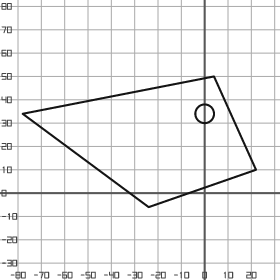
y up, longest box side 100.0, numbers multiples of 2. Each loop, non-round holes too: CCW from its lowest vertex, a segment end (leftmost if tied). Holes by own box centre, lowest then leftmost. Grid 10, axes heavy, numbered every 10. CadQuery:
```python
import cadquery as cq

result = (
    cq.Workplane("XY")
    .moveTo(-24.0, -6.0)
    .lineTo(22.0, 10.0)
    .lineTo(4.0, 50.0)
    .lineTo(-78.0, 34.0)
    .close()
    .moveTo(0.0, 34.0)
    .circle(4.0)
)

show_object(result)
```